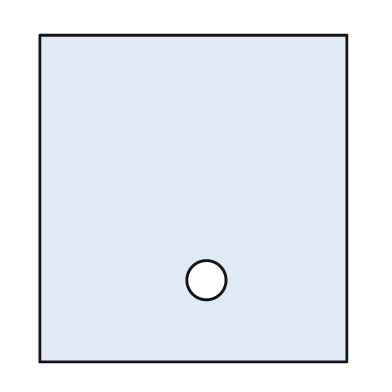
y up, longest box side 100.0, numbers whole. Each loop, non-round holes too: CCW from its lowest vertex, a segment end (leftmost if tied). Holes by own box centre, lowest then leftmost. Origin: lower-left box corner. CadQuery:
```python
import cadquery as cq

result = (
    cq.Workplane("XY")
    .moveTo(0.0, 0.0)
    .lineTo(94.0, 0.0)
    .lineTo(94.0, 100.0)
    .lineTo(0.0, 100.0)
    .close()
    .moveTo(51.0, 25.0)
    .circle(6.0)
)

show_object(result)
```